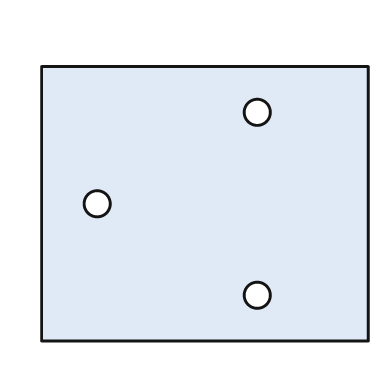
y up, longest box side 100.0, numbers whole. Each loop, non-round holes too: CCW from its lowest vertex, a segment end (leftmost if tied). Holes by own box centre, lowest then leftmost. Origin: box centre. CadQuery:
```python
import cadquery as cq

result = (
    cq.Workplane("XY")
    .moveTo(-50.0, -42.0)
    .lineTo(50.0, -42.0)
    .lineTo(50.0, 42.0)
    .lineTo(-50.0, 42.0)
    .close()
    .moveTo(16.0, -28.0)
    .circle(4.0)
    .moveTo(-33.0, 0.0)
    .circle(4.0)
    .moveTo(16.0, 28.0)
    .circle(4.0)
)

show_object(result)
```